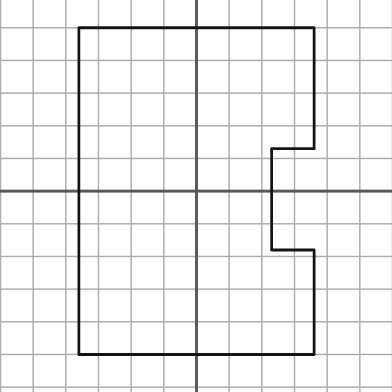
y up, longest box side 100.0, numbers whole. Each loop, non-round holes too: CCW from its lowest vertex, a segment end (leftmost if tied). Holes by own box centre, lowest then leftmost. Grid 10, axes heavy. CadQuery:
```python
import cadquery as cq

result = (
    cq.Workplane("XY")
    .moveTo(-36.0, -50.0)
    .lineTo(36.0, -50.0)
    .lineTo(36.0, -18.0)
    .lineTo(23.0, -18.0)
    .lineTo(23.0, 13.0)
    .lineTo(36.0, 13.0)
    .lineTo(36.0, 50.0)
    .lineTo(-36.0, 50.0)
    .close()
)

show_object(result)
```